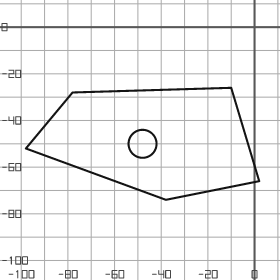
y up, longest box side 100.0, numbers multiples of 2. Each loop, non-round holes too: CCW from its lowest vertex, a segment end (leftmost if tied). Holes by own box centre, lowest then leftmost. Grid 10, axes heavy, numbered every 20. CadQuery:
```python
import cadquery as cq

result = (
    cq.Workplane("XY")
    .moveTo(-38.0, -74.0)
    .lineTo(2.0, -66.0)
    .lineTo(-10.0, -26.0)
    .lineTo(-78.0, -28.0)
    .lineTo(-98.0, -52.0)
    .close()
    .moveTo(-48.0, -50.0)
    .circle(6.0)
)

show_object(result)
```